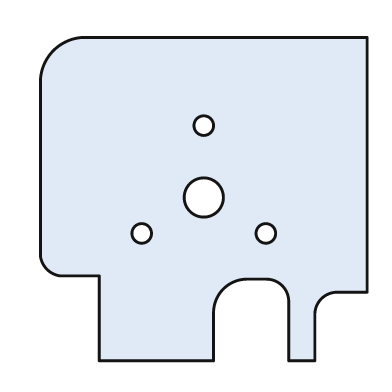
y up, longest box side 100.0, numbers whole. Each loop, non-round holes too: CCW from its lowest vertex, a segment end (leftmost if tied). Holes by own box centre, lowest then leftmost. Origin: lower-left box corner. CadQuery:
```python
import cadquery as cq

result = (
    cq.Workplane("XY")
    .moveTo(18.0, 0.0)
    .lineTo(53.0, 0.0)
    .lineTo(53.0, 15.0)
    .threePointArc((56.0, 22.0), (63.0, 25.0))
    .lineTo(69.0, 25.0)
    .threePointArc((74.0, 23.0), (76.0, 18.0))
    .lineTo(76.0, 0.0)
    .lineTo(84.0, 0.0)
    .lineTo(84.0, 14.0)
    .threePointArc((86.0, 19.0), (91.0, 21.0))
    .lineTo(100.0, 21.0)
    .lineTo(100.0, 99.0)
    .lineTo(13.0, 99.0)
    .threePointArc((4.0, 95.0), (0.0, 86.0))
    .lineTo(0.0, 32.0)
    .threePointArc((2.0, 28.0), (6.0, 26.0))
    .lineTo(18.0, 26.0)
    .close()
    .moveTo(31.0, 39.0)
    .circle(3.0)
    .moveTo(69.0, 39.0)
    .circle(3.0)
    .moveTo(50.0, 50.0)
    .circle(6.0)
    .moveTo(50.0, 72.0)
    .circle(3.0)
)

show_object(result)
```